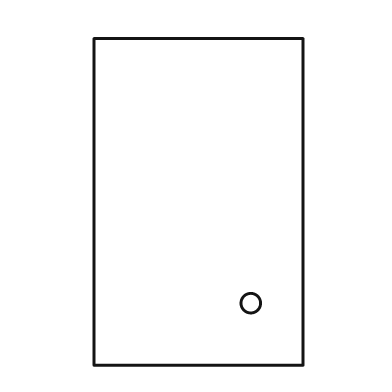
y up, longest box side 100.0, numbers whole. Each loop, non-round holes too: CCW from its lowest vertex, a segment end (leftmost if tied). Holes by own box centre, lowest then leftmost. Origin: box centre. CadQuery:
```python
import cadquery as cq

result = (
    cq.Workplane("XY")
    .moveTo(-32.0, -50.0)
    .lineTo(32.0, -50.0)
    .lineTo(32.0, 50.0)
    .lineTo(-32.0, 50.0)
    .close()
    .moveTo(16.0, -31.0)
    .circle(3.0)
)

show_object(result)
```